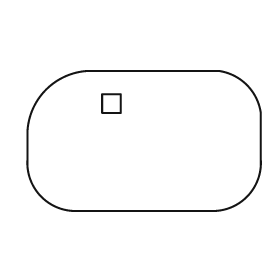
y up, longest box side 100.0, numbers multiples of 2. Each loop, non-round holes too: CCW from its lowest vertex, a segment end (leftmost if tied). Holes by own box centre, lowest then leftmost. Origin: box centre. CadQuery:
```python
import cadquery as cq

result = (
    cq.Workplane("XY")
    .moveTo(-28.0, -30.0)
    .lineTo(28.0, -30.0)
    .threePointArc((44.0, -24.0), (50.0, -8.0))
    .lineTo(50.0, 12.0)
    .threePointArc((44.0, 24.0), (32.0, 30.0))
    .lineTo(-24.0, 30.0)
    .threePointArc((-42.0, 22.0), (-50.0, 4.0))
    .lineTo(-50.0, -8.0)
    .threePointArc((-44.0, -24.0), (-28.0, -30.0))
    .close()
    .moveTo(-18.0, 12.0)
    .lineTo(-10.0, 12.0)
    .lineTo(-10.0, 20.0)
    .lineTo(-18.0, 20.0)
    .close()
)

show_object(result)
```